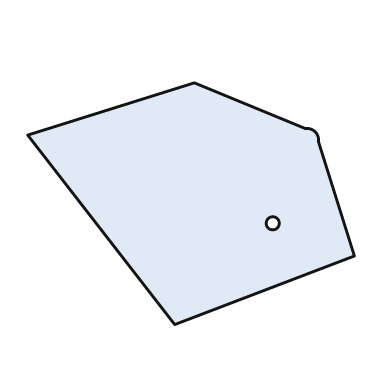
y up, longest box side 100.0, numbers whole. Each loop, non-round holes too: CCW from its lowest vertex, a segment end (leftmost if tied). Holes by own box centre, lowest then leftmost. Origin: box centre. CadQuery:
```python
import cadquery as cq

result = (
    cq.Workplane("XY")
    .moveTo(-5.0, -37.0)
    .lineTo(50.0, -16.0)
    .lineTo(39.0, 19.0)
    .threePointArc((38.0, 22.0), (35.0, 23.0))
    .lineTo(1.0, 37.0)
    .lineTo(-50.0, 21.0)
    .close()
    .moveTo(25.0, -6.0)
    .circle(2.0)
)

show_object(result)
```